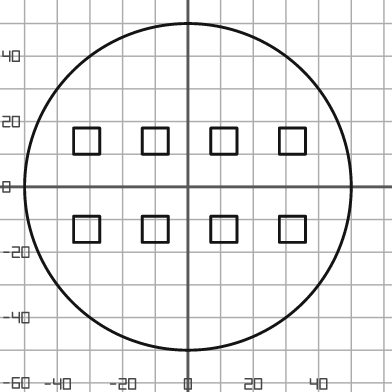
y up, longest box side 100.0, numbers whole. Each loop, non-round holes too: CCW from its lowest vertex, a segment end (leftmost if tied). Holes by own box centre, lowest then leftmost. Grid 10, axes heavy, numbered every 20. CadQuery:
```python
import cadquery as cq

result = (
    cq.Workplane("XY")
    .moveTo(0.0, 0.0)
    .circle(50.0)
    .moveTo(-35.0, -17.0)
    .lineTo(-27.0, -17.0)
    .lineTo(-27.0, -9.0)
    .lineTo(-35.0, -9.0)
    .close()
    .moveTo(-14.0, -17.0)
    .lineTo(-6.0, -17.0)
    .lineTo(-6.0, -9.0)
    .lineTo(-14.0, -9.0)
    .close()
    .moveTo(7.0, -17.0)
    .lineTo(15.0, -17.0)
    .lineTo(15.0, -9.0)
    .lineTo(7.0, -9.0)
    .close()
    .moveTo(28.0, -17.0)
    .lineTo(36.0, -17.0)
    .lineTo(36.0, -9.0)
    .lineTo(28.0, -9.0)
    .close()
    .moveTo(-35.0, 10.0)
    .lineTo(-27.0, 10.0)
    .lineTo(-27.0, 18.0)
    .lineTo(-35.0, 18.0)
    .close()
    .moveTo(-14.0, 10.0)
    .lineTo(-6.0, 10.0)
    .lineTo(-6.0, 18.0)
    .lineTo(-14.0, 18.0)
    .close()
    .moveTo(7.0, 10.0)
    .lineTo(15.0, 10.0)
    .lineTo(15.0, 18.0)
    .lineTo(7.0, 18.0)
    .close()
    .moveTo(28.0, 10.0)
    .lineTo(36.0, 10.0)
    .lineTo(36.0, 18.0)
    .lineTo(28.0, 18.0)
    .close()
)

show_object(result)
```